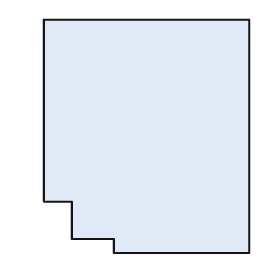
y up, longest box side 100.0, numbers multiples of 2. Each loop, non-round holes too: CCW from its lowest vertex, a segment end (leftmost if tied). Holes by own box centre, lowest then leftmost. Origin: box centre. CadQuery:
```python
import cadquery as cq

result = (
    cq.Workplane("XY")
    .moveTo(-14.0, -50.0)
    .lineTo(44.0, -50.0)
    .lineTo(44.0, 50.0)
    .lineTo(-44.0, 50.0)
    .lineTo(-44.0, -28.0)
    .lineTo(-32.0, -28.0)
    .lineTo(-32.0, -44.0)
    .lineTo(-14.0, -44.0)
    .close()
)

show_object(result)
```